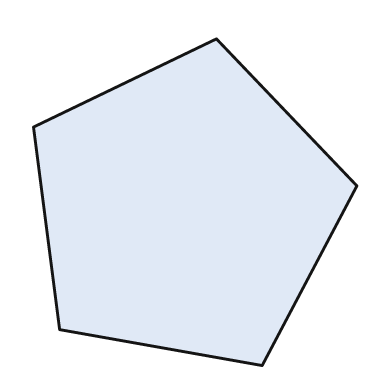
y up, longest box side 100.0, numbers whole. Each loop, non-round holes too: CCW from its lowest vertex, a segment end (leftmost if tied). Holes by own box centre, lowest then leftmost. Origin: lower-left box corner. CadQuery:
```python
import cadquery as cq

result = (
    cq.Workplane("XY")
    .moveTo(70.0, 0.0)
    .lineTo(99.0, 55.0)
    .lineTo(56.0, 100.0)
    .lineTo(0.0, 73.0)
    .lineTo(8.0, 11.0)
    .close()
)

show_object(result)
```